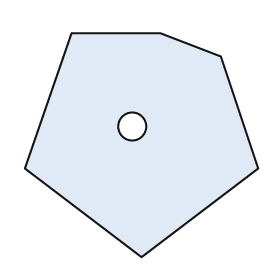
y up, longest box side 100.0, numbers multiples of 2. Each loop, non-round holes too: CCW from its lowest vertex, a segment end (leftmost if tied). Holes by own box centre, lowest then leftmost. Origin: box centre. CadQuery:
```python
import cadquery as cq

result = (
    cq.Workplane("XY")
    .moveTo(0.0, -48.0)
    .lineTo(50.0, -10.0)
    .lineTo(34.0, 38.0)
    .lineTo(8.0, 48.0)
    .lineTo(-30.0, 48.0)
    .lineTo(-50.0, -10.0)
    .close()
    .moveTo(-4.0, 8.0)
    .circle(6.0)
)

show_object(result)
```